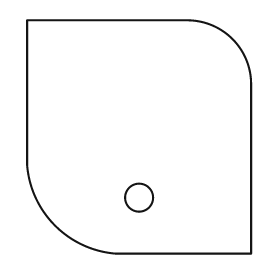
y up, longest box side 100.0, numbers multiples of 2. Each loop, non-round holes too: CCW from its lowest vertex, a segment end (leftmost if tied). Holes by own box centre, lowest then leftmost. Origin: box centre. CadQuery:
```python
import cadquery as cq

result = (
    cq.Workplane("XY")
    .moveTo(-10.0, -50.0)
    .lineTo(48.0, -50.0)
    .lineTo(48.0, 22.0)
    .threePointArc((40.0, 42.0), (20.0, 50.0))
    .lineTo(-48.0, 50.0)
    .lineTo(-48.0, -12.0)
    .threePointArc((-36.0, -38.0), (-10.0, -50.0))
    .close()
    .moveTo(0.0, -26.0)
    .circle(6.0)
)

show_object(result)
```